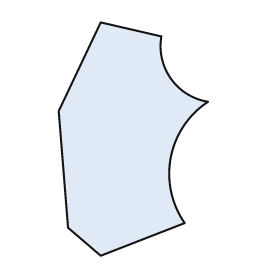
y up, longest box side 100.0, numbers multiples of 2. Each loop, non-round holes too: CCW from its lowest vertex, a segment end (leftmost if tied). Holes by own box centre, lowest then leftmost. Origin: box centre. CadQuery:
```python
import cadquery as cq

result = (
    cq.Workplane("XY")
    .moveTo(-14.0, -50.0)
    .lineTo(22.0, -36.0)
    .threePointArc((16.0, -8.0), (32.0, 16.0))
    .threePointArc((16.0, 26.0), (12.0, 44.0))
    .lineTo(-14.0, 50.0)
    .lineTo(-32.0, 12.0)
    .lineTo(-28.0, -38.0)
    .close()
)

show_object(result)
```